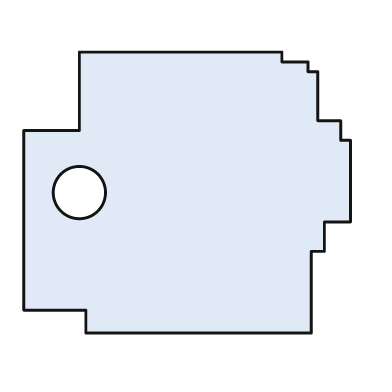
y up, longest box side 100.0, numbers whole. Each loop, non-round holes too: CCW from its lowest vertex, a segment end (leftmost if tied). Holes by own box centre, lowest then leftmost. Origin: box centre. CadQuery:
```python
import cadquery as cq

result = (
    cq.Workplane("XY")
    .moveTo(-31.0, -43.0)
    .lineTo(38.0, -43.0)
    .lineTo(38.0, -18.0)
    .lineTo(42.0, -18.0)
    .lineTo(42.0, -9.0)
    .lineTo(50.0, -9.0)
    .lineTo(50.0, 16.0)
    .lineTo(47.0, 16.0)
    .lineTo(47.0, 22.0)
    .lineTo(40.0, 22.0)
    .lineTo(40.0, 37.0)
    .lineTo(37.0, 37.0)
    .lineTo(37.0, 40.0)
    .lineTo(29.0, 40.0)
    .lineTo(29.0, 43.0)
    .lineTo(-33.0, 43.0)
    .lineTo(-33.0, 19.0)
    .lineTo(-50.0, 19.0)
    .lineTo(-50.0, -36.0)
    .lineTo(-31.0, -36.0)
    .close()
    .moveTo(-33.0, 0.0)
    .circle(8.0)
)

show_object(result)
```